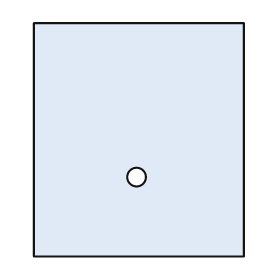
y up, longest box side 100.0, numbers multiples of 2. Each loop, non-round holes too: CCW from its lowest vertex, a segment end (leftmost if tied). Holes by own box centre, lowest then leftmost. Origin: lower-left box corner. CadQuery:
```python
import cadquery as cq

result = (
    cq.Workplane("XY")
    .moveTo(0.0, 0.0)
    .lineTo(90.0, 0.0)
    .lineTo(90.0, 100.0)
    .lineTo(0.0, 100.0)
    .close()
    .moveTo(44.0, 34.0)
    .circle(4.0)
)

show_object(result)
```